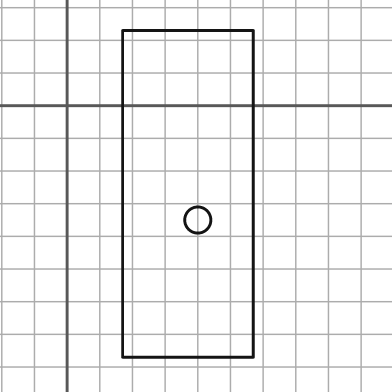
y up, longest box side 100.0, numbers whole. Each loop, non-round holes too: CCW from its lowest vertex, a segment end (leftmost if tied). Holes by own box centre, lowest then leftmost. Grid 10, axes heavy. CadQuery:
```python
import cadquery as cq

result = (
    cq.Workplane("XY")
    .moveTo(17.0, -77.0)
    .lineTo(57.0, -77.0)
    .lineTo(57.0, 23.0)
    .lineTo(17.0, 23.0)
    .close()
    .moveTo(40.0, -35.0)
    .circle(4.0)
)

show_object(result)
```